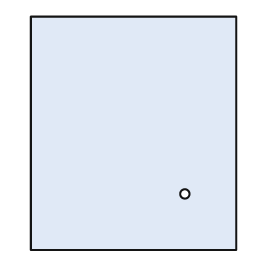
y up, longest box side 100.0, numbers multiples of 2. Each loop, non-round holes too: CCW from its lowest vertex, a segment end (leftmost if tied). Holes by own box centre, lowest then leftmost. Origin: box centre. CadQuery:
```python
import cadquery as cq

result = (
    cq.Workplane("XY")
    .moveTo(-44.0, -50.0)
    .lineTo(44.0, -50.0)
    .lineTo(44.0, 50.0)
    .lineTo(-44.0, 50.0)
    .close()
    .moveTo(22.0, -26.0)
    .circle(2.0)
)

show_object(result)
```